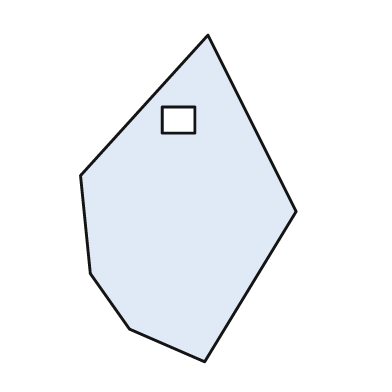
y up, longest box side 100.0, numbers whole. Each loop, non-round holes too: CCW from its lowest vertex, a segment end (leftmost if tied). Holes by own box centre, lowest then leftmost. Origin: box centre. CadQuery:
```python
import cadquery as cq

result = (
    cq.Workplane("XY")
    .moveTo(5.0, -50.0)
    .lineTo(33.0, -4.0)
    .lineTo(6.0, 50.0)
    .lineTo(-33.0, 7.0)
    .lineTo(-30.0, -23.0)
    .lineTo(-18.0, -40.0)
    .close()
    .moveTo(-8.0, 20.0)
    .lineTo(2.0, 20.0)
    .lineTo(2.0, 28.0)
    .lineTo(-8.0, 28.0)
    .close()
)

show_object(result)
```